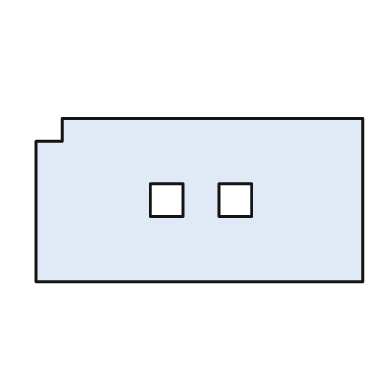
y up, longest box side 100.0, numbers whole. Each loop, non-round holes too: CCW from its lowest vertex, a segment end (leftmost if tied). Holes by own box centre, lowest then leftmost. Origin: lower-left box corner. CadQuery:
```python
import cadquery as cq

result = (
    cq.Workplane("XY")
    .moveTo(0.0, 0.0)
    .lineTo(100.0, 0.0)
    .lineTo(100.0, 50.0)
    .lineTo(8.0, 50.0)
    .lineTo(8.0, 43.0)
    .lineTo(0.0, 43.0)
    .close()
    .moveTo(35.0, 20.0)
    .lineTo(45.0, 20.0)
    .lineTo(45.0, 30.0)
    .lineTo(35.0, 30.0)
    .close()
    .moveTo(56.0, 20.0)
    .lineTo(66.0, 20.0)
    .lineTo(66.0, 30.0)
    .lineTo(56.0, 30.0)
    .close()
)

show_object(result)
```